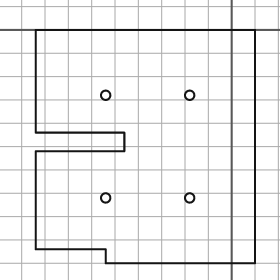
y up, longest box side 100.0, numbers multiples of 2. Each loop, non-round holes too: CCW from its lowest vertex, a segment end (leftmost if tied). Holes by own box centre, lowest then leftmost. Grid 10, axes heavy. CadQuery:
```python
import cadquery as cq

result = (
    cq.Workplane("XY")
    .moveTo(-54.0, -100.0)
    .lineTo(10.0, -100.0)
    .lineTo(10.0, 0.0)
    .lineTo(-84.0, 0.0)
    .lineTo(-84.0, -44.0)
    .lineTo(-46.0, -44.0)
    .lineTo(-46.0, -52.0)
    .lineTo(-84.0, -52.0)
    .lineTo(-84.0, -94.0)
    .lineTo(-54.0, -94.0)
    .close()
    .moveTo(-54.0, -72.0)
    .circle(2.0)
    .moveTo(-18.0, -72.0)
    .circle(2.0)
    .moveTo(-54.0, -28.0)
    .circle(2.0)
    .moveTo(-18.0, -28.0)
    .circle(2.0)
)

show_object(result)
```